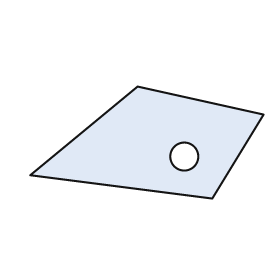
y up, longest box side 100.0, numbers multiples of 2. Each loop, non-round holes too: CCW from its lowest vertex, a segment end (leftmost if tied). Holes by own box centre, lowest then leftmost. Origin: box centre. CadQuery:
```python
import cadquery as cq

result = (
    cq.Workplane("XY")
    .moveTo(28.0, -24.0)
    .lineTo(50.0, 12.0)
    .lineTo(-4.0, 24.0)
    .lineTo(-50.0, -14.0)
    .close()
    .moveTo(16.0, -6.0)
    .circle(6.0)
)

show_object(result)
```